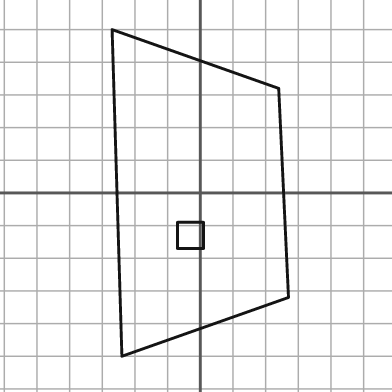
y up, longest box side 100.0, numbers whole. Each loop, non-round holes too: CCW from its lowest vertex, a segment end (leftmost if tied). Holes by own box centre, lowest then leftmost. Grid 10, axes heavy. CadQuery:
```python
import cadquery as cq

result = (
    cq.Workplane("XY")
    .moveTo(-24.0, -50.0)
    .lineTo(27.0, -32.0)
    .lineTo(24.0, 32.0)
    .lineTo(-27.0, 50.0)
    .close()
    .moveTo(-7.0, -17.0)
    .lineTo(1.0, -17.0)
    .lineTo(1.0, -9.0)
    .lineTo(-7.0, -9.0)
    .close()
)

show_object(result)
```